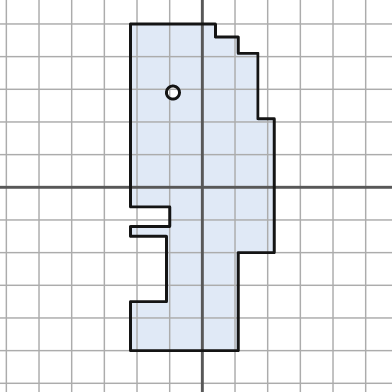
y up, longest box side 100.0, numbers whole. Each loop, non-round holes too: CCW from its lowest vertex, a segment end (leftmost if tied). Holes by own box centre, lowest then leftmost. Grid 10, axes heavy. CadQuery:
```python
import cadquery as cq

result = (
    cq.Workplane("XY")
    .moveTo(-22.0, -50.0)
    .lineTo(11.0, -50.0)
    .lineTo(11.0, -20.0)
    .lineTo(22.0, -20.0)
    .lineTo(22.0, 21.0)
    .lineTo(17.0, 21.0)
    .lineTo(17.0, 41.0)
    .lineTo(11.0, 41.0)
    .lineTo(11.0, 46.0)
    .lineTo(4.0, 46.0)
    .lineTo(4.0, 50.0)
    .lineTo(-22.0, 50.0)
    .lineTo(-22.0, -6.0)
    .lineTo(-10.0, -6.0)
    .lineTo(-10.0, -12.0)
    .lineTo(-22.0, -12.0)
    .lineTo(-22.0, -15.0)
    .lineTo(-11.0, -15.0)
    .lineTo(-11.0, -35.0)
    .lineTo(-22.0, -35.0)
    .close()
    .moveTo(-9.0, 29.0)
    .circle(2.0)
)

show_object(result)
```